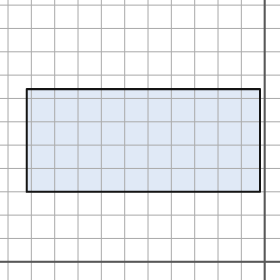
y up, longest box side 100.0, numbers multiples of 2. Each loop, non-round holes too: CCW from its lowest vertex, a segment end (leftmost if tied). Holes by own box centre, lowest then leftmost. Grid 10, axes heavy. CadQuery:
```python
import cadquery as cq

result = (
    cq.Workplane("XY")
    .moveTo(-102.0, 30.0)
    .lineTo(-2.0, 30.0)
    .lineTo(-2.0, 74.0)
    .lineTo(-102.0, 74.0)
    .close()
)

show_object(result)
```